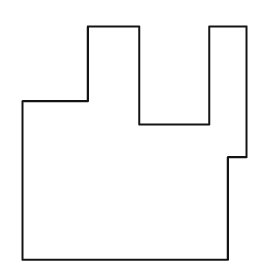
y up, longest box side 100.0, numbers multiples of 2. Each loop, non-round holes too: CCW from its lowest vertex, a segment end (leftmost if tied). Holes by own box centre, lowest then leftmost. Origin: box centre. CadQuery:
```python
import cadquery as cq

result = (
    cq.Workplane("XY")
    .moveTo(-48.0, -50.0)
    .lineTo(40.0, -50.0)
    .lineTo(40.0, -6.0)
    .lineTo(48.0, -6.0)
    .lineTo(48.0, 50.0)
    .lineTo(32.0, 50.0)
    .lineTo(32.0, 8.0)
    .lineTo(2.0, 8.0)
    .lineTo(2.0, 50.0)
    .lineTo(-20.0, 50.0)
    .lineTo(-20.0, 18.0)
    .lineTo(-48.0, 18.0)
    .close()
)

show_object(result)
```